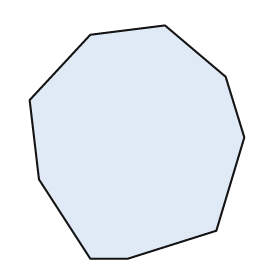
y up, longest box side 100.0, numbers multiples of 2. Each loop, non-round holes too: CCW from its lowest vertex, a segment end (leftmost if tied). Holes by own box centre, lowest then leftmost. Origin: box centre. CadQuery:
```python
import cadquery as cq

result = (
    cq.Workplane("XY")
    .moveTo(-20.0, -50.0)
    .lineTo(-4.0, -50.0)
    .lineTo(34.0, -38.0)
    .lineTo(46.0, 2.0)
    .lineTo(38.0, 28.0)
    .lineTo(12.0, 50.0)
    .lineTo(-20.0, 46.0)
    .lineTo(-46.0, 18.0)
    .lineTo(-42.0, -16.0)
    .close()
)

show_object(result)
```